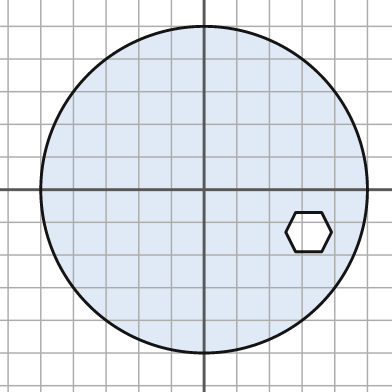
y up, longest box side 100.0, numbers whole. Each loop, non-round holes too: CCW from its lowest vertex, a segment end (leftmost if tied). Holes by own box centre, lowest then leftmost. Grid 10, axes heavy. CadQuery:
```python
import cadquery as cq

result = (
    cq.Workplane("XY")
    .moveTo(0.0, 0.0)
    .circle(50.0)
    .moveTo(28.0, -19.0)
    .lineTo(36.0, -19.0)
    .lineTo(39.0, -13.0)
    .lineTo(36.0, -7.0)
    .lineTo(28.0, -7.0)
    .lineTo(25.0, -13.0)
    .close()
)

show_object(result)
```